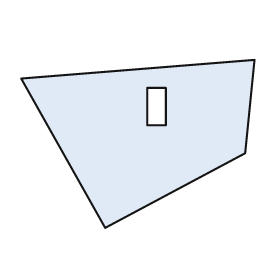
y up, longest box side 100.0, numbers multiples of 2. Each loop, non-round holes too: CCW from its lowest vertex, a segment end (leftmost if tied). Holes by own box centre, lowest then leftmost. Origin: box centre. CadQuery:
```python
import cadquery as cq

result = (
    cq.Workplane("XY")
    .moveTo(-14.0, -36.0)
    .lineTo(46.0, -4.0)
    .lineTo(50.0, 36.0)
    .lineTo(-50.0, 28.0)
    .close()
    .moveTo(4.0, 8.0)
    .lineTo(12.0, 8.0)
    .lineTo(12.0, 24.0)
    .lineTo(4.0, 24.0)
    .close()
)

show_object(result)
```